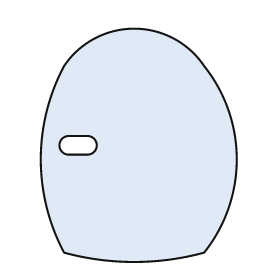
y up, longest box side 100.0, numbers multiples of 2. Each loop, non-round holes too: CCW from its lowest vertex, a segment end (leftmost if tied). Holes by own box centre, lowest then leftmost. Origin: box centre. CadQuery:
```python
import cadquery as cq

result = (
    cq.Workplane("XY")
    .moveTo(-32.0, -46.0)
    .threePointArc((-2.0, -50.0), (28.0, -46.0))
    .threePointArc((42.0, -6.0), (28.0, 34.0))
    .threePointArc((-2.0, 50.0), (-32.0, 34.0))
    .threePointArc((-42.0, -6.0), (-32.0, -46.0))
    .close()
    .moveTo(-30.0, -4.0)
    .lineTo(-22.0, -4.0)
    .threePointArc((-18.0, 0.0), (-22.0, 4.0))
    .lineTo(-30.0, 4.0)
    .threePointArc((-34.0, 0.0), (-30.0, -4.0))
    .close()
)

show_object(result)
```